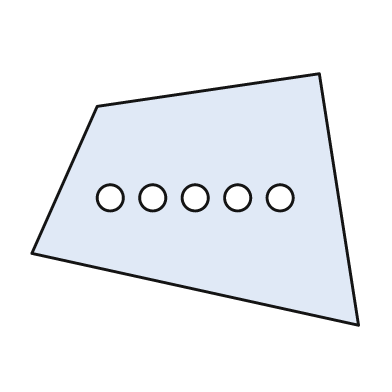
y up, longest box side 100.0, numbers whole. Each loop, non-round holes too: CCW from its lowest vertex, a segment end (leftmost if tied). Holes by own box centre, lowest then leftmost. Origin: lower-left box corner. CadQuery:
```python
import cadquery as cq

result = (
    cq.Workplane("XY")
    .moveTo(100.0, 0.0)
    .lineTo(88.0, 77.0)
    .lineTo(20.0, 67.0)
    .lineTo(0.0, 22.0)
    .close()
    .moveTo(24.0, 39.0)
    .circle(4.0)
    .moveTo(37.0, 39.0)
    .circle(4.0)
    .moveTo(50.0, 39.0)
    .circle(4.0)
    .moveTo(63.0, 39.0)
    .circle(4.0)
    .moveTo(76.0, 39.0)
    .circle(4.0)
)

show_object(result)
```